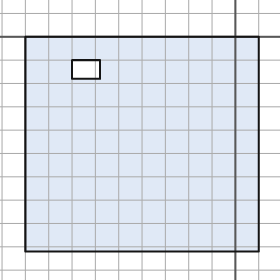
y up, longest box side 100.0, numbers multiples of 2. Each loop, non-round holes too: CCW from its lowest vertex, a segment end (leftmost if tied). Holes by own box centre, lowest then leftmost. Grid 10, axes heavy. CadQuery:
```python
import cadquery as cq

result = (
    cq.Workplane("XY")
    .moveTo(-90.0, -92.0)
    .lineTo(10.0, -92.0)
    .lineTo(10.0, 0.0)
    .lineTo(-90.0, 0.0)
    .close()
    .moveTo(-70.0, -18.0)
    .lineTo(-58.0, -18.0)
    .lineTo(-58.0, -10.0)
    .lineTo(-70.0, -10.0)
    .close()
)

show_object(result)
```